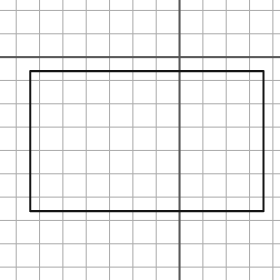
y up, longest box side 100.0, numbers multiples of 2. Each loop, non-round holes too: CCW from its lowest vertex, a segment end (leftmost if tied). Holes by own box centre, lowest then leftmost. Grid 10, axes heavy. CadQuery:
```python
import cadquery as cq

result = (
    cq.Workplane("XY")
    .moveTo(-64.0, -66.0)
    .lineTo(36.0, -66.0)
    .lineTo(36.0, -6.0)
    .lineTo(-64.0, -6.0)
    .close()
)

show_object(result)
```